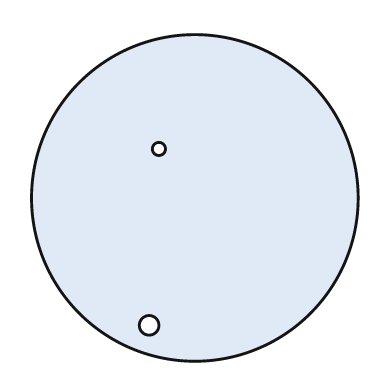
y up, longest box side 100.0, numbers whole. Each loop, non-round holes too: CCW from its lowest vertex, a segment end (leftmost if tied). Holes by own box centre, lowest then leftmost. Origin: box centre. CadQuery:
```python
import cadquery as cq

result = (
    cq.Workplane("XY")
    .moveTo(0.0, 0.0)
    .circle(50.0)
    .moveTo(-14.0, -39.0)
    .circle(3.0)
    .moveTo(-11.0, 15.0)
    .circle(2.0)
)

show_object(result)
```